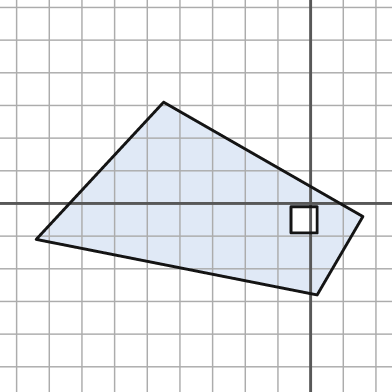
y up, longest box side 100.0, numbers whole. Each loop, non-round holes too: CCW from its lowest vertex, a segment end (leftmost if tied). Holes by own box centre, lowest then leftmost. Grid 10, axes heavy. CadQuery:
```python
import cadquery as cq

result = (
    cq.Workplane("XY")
    .moveTo(2.0, -28.0)
    .lineTo(16.0, -4.0)
    .lineTo(-45.0, 31.0)
    .lineTo(-84.0, -11.0)
    .close()
    .moveTo(-6.0, -9.0)
    .lineTo(2.0, -9.0)
    .lineTo(2.0, -1.0)
    .lineTo(-6.0, -1.0)
    .close()
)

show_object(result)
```